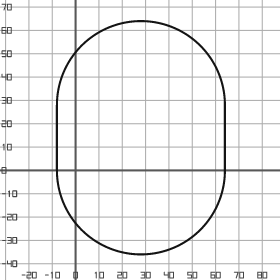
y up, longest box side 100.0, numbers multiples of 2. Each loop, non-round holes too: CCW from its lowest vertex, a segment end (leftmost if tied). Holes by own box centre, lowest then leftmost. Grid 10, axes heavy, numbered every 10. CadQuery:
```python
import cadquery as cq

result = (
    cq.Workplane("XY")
    .moveTo(-8.0, 0.0)
    .threePointArc((28.0, -36.0), (64.0, 0.0))
    .lineTo(64.0, 28.0)
    .threePointArc((28.0, 64.0), (-8.0, 28.0))
    .close()
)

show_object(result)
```